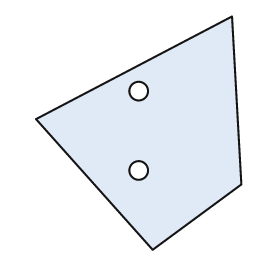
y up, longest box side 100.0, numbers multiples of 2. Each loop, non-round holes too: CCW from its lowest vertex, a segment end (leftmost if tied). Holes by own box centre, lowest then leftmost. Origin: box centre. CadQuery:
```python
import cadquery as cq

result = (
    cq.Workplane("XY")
    .moveTo(6.0, -50.0)
    .lineTo(44.0, -22.0)
    .lineTo(40.0, 50.0)
    .lineTo(-44.0, 6.0)
    .close()
    .moveTo(0.0, -16.0)
    .circle(4.0)
    .moveTo(0.0, 18.0)
    .circle(4.0)
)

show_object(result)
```